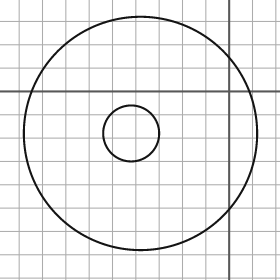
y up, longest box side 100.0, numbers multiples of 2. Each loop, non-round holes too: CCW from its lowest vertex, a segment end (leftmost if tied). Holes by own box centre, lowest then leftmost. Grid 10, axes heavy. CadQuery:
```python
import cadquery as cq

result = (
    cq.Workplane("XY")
    .moveTo(-38.0, -18.0)
    .circle(50.0)
    .moveTo(-42.0, -18.0)
    .circle(12.0)
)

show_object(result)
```